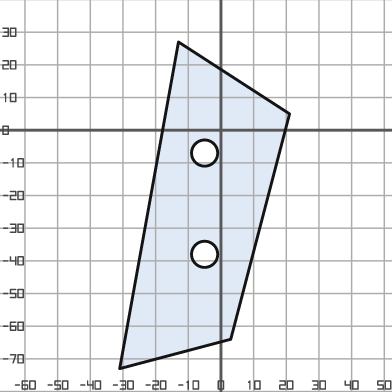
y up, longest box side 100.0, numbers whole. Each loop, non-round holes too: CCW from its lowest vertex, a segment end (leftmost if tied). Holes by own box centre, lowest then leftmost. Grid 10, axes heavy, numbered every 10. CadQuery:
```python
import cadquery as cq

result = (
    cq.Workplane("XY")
    .moveTo(-31.0, -73.0)
    .lineTo(3.0, -64.0)
    .lineTo(21.0, 5.0)
    .lineTo(-13.0, 27.0)
    .close()
    .moveTo(-5.0, -38.0)
    .circle(4.0)
    .moveTo(-5.0, -7.0)
    .circle(4.0)
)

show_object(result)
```